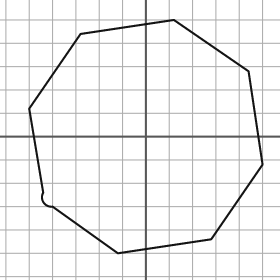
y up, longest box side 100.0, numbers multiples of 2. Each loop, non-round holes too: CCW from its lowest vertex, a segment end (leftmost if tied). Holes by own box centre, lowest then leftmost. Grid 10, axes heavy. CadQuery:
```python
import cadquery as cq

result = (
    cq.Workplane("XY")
    .moveTo(-12.0, -50.0)
    .lineTo(28.0, -44.0)
    .lineTo(50.0, -12.0)
    .lineTo(44.0, 28.0)
    .lineTo(12.0, 50.0)
    .lineTo(-28.0, 44.0)
    .lineTo(-50.0, 12.0)
    .lineTo(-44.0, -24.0)
    .threePointArc((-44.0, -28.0), (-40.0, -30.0))
    .close()
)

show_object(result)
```